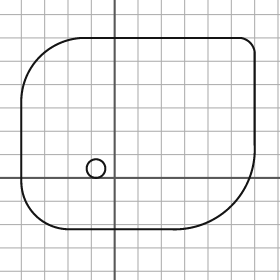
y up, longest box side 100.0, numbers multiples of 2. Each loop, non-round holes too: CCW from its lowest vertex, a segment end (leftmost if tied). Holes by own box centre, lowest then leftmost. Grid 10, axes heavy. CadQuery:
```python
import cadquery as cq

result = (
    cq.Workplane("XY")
    .moveTo(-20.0, -22.0)
    .lineTo(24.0, -22.0)
    .threePointArc((50.0, -12.0), (60.0, 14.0))
    .lineTo(60.0, 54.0)
    .threePointArc((58.0, 58.0), (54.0, 60.0))
    .lineTo(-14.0, 60.0)
    .threePointArc((-32.0, 52.0), (-40.0, 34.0))
    .lineTo(-40.0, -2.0)
    .threePointArc((-34.0, -16.0), (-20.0, -22.0))
    .close()
    .moveTo(-8.0, 4.0)
    .circle(4.0)
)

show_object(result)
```